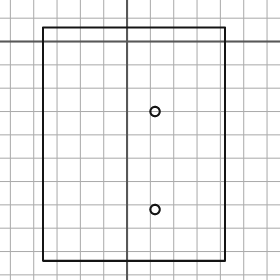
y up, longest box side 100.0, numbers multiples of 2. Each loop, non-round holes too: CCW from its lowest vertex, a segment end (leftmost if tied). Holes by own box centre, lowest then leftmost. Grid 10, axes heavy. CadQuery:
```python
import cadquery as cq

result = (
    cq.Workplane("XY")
    .moveTo(-36.0, -94.0)
    .lineTo(42.0, -94.0)
    .lineTo(42.0, 6.0)
    .lineTo(-36.0, 6.0)
    .close()
    .moveTo(12.0, -72.0)
    .circle(2.0)
    .moveTo(12.0, -30.0)
    .circle(2.0)
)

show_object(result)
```